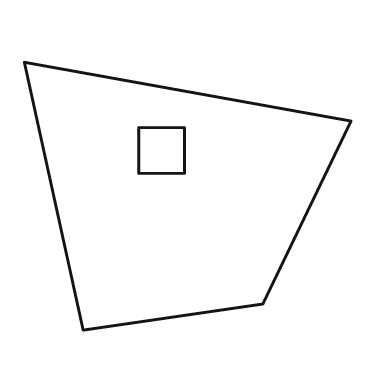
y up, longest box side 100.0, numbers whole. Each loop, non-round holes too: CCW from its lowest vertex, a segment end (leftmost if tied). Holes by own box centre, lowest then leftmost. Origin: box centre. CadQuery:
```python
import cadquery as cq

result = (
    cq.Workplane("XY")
    .moveTo(-32.0, -41.0)
    .lineTo(23.0, -33.0)
    .lineTo(50.0, 23.0)
    .lineTo(-50.0, 41.0)
    .close()
    .moveTo(-15.0, 7.0)
    .lineTo(-1.0, 7.0)
    .lineTo(-1.0, 21.0)
    .lineTo(-15.0, 21.0)
    .close()
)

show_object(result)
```